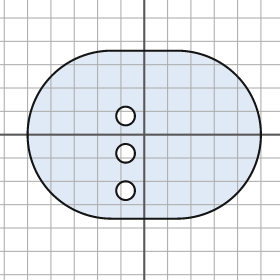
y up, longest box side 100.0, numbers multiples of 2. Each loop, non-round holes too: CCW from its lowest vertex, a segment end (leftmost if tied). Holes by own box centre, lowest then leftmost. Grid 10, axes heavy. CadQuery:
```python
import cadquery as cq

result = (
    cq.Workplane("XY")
    .moveTo(-14.0, -36.0)
    .lineTo(14.0, -36.0)
    .threePointArc((50.0, 0.0), (14.0, 36.0))
    .lineTo(-14.0, 36.0)
    .threePointArc((-50.0, 0.0), (-14.0, -36.0))
    .close()
    .moveTo(-8.0, -24.0)
    .circle(4.0)
    .moveTo(-8.0, -8.0)
    .circle(4.0)
    .moveTo(-8.0, 8.0)
    .circle(4.0)
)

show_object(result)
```